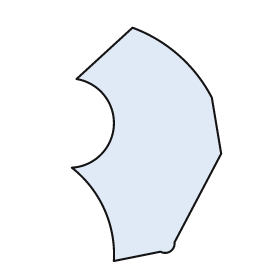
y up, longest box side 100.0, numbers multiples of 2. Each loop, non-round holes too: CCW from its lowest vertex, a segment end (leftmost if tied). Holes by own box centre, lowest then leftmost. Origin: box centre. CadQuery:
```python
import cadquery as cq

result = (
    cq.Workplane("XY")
    .moveTo(-14.0, -50.0)
    .lineTo(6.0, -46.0)
    .threePointArc((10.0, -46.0), (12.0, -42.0))
    .lineTo(32.0, -4.0)
    .lineTo(28.0, 20.0)
    .threePointArc((14.0, 38.0), (-6.0, 50.0))
    .lineTo(-30.0, 28.0)
    .threePointArc((-14.0, 8.0), (-32.0, -10.0))
    .threePointArc((-18.0, -28.0), (-14.0, -50.0))
    .close()
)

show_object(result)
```